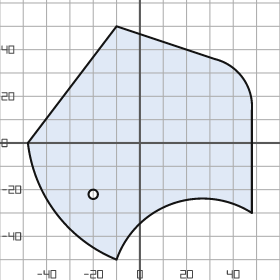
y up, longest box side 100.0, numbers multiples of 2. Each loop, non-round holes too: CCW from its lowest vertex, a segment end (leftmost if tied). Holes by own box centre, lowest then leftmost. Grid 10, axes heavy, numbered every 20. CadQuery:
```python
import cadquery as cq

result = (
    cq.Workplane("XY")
    .moveTo(-10.0, -50.0)
    .threePointArc((14.0, -26.0), (48.0, -30.0))
    .lineTo(48.0, 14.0)
    .threePointArc((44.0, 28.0), (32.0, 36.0))
    .lineTo(-10.0, 50.0)
    .lineTo(-48.0, 0.0)
    .threePointArc((-36.0, -30.0), (-10.0, -50.0))
    .close()
    .moveTo(-20.0, -22.0)
    .circle(2.0)
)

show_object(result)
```